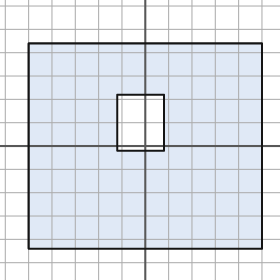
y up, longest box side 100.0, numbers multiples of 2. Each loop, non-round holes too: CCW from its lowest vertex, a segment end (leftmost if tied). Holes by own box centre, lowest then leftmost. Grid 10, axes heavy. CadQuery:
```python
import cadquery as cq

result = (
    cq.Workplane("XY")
    .moveTo(-50.0, -44.0)
    .lineTo(50.0, -44.0)
    .lineTo(50.0, 44.0)
    .lineTo(-50.0, 44.0)
    .close()
    .moveTo(-12.0, -2.0)
    .lineTo(8.0, -2.0)
    .lineTo(8.0, 22.0)
    .lineTo(-12.0, 22.0)
    .close()
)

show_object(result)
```